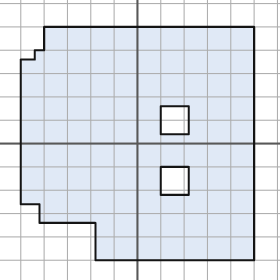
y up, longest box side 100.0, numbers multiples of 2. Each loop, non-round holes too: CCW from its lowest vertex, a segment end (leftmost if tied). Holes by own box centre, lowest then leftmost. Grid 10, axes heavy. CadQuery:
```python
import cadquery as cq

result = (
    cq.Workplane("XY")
    .moveTo(-18.0, -50.0)
    .lineTo(50.0, -50.0)
    .lineTo(50.0, 50.0)
    .lineTo(-40.0, 50.0)
    .lineTo(-40.0, 40.0)
    .lineTo(-44.0, 40.0)
    .lineTo(-44.0, 36.0)
    .lineTo(-50.0, 36.0)
    .lineTo(-50.0, -26.0)
    .lineTo(-42.0, -26.0)
    .lineTo(-42.0, -34.0)
    .lineTo(-18.0, -34.0)
    .close()
    .moveTo(10.0, -22.0)
    .lineTo(22.0, -22.0)
    .lineTo(22.0, -10.0)
    .lineTo(10.0, -10.0)
    .close()
    .moveTo(10.0, 4.0)
    .lineTo(22.0, 4.0)
    .lineTo(22.0, 16.0)
    .lineTo(10.0, 16.0)
    .close()
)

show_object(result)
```